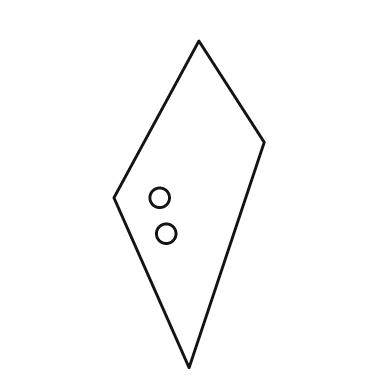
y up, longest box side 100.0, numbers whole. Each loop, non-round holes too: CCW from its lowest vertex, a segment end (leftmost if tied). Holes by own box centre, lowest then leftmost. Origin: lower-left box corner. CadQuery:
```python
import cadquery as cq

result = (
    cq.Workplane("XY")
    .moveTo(23.0, 0.0)
    .lineTo(46.0, 69.0)
    .lineTo(26.0, 100.0)
    .lineTo(0.0, 52.0)
    .close()
    .moveTo(16.0, 41.0)
    .circle(3.0)
    .moveTo(14.0, 52.0)
    .circle(3.0)
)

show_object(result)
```